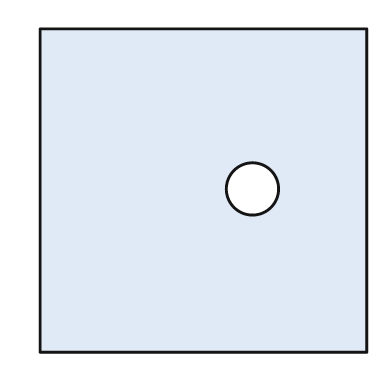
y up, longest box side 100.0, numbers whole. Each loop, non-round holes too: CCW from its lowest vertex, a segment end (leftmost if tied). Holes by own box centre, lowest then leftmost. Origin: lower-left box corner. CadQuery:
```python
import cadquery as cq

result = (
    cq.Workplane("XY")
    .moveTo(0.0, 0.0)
    .lineTo(100.0, 0.0)
    .lineTo(100.0, 99.0)
    .lineTo(0.0, 99.0)
    .close()
    .moveTo(65.0, 50.0)
    .circle(8.0)
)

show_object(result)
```